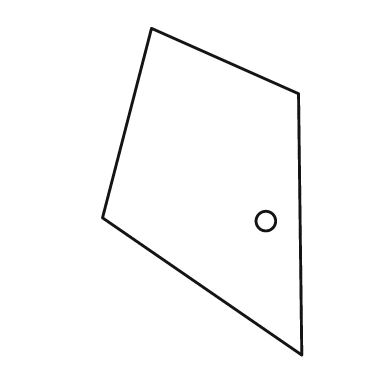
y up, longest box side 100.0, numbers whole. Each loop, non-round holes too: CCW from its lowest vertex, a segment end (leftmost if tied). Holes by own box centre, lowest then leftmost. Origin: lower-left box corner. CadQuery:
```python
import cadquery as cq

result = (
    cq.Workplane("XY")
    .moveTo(61.0, 0.0)
    .lineTo(60.0, 80.0)
    .lineTo(15.0, 100.0)
    .lineTo(0.0, 42.0)
    .close()
    .moveTo(50.0, 41.0)
    .circle(3.0)
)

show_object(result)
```